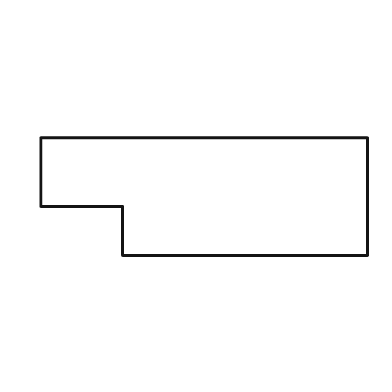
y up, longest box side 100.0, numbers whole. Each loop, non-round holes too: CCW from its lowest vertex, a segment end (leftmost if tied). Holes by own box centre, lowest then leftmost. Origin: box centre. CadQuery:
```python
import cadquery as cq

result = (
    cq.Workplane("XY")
    .moveTo(-25.0, -18.0)
    .lineTo(50.0, -18.0)
    .lineTo(50.0, 18.0)
    .lineTo(-50.0, 18.0)
    .lineTo(-50.0, -3.0)
    .lineTo(-25.0, -3.0)
    .close()
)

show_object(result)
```